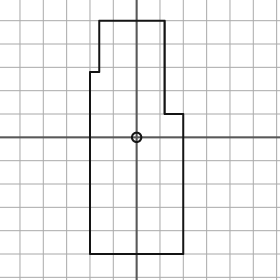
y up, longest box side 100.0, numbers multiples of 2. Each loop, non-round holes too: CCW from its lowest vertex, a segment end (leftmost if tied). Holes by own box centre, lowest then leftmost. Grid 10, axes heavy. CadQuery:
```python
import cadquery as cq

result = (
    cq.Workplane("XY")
    .moveTo(-20.0, -50.0)
    .lineTo(20.0, -50.0)
    .lineTo(20.0, 10.0)
    .lineTo(12.0, 10.0)
    .lineTo(12.0, 50.0)
    .lineTo(-16.0, 50.0)
    .lineTo(-16.0, 28.0)
    .lineTo(-20.0, 28.0)
    .close()
    .moveTo(0.0, 0.0)
    .circle(2.0)
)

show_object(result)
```